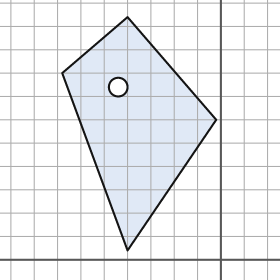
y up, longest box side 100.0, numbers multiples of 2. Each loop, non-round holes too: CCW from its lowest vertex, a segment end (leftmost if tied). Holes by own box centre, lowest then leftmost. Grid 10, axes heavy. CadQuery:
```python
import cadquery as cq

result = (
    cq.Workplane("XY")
    .moveTo(-40.0, 4.0)
    .lineTo(-2.0, 60.0)
    .lineTo(-40.0, 104.0)
    .lineTo(-68.0, 80.0)
    .close()
    .moveTo(-44.0, 74.0)
    .circle(4.0)
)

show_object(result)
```